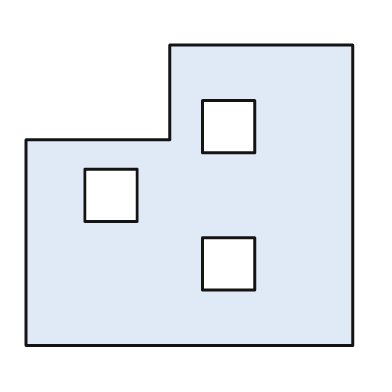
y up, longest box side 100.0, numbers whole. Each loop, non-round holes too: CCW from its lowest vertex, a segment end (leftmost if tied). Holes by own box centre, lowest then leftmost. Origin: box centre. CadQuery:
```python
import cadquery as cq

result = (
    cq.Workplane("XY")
    .moveTo(-50.0, -46.0)
    .lineTo(50.0, -46.0)
    .lineTo(50.0, 46.0)
    .lineTo(-6.0, 46.0)
    .lineTo(-6.0, 17.0)
    .lineTo(-50.0, 17.0)
    .close()
    .moveTo(4.0, -29.0)
    .lineTo(20.0, -29.0)
    .lineTo(20.0, -13.0)
    .lineTo(4.0, -13.0)
    .close()
    .moveTo(-32.0, -8.0)
    .lineTo(-16.0, -8.0)
    .lineTo(-16.0, 8.0)
    .lineTo(-32.0, 8.0)
    .close()
    .moveTo(4.0, 13.0)
    .lineTo(20.0, 13.0)
    .lineTo(20.0, 29.0)
    .lineTo(4.0, 29.0)
    .close()
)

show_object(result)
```